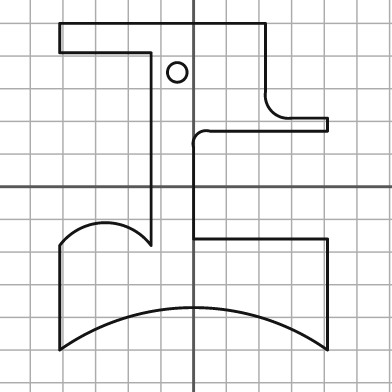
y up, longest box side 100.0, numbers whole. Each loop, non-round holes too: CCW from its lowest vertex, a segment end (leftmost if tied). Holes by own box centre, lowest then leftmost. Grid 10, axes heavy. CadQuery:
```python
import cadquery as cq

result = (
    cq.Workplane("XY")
    .moveTo(-41.0, -50.0)
    .threePointArc((0.0, -37.0), (41.0, -50.0))
    .lineTo(41.0, -16.0)
    .lineTo(0.0, -16.0)
    .lineTo(0.0, 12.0)
    .threePointArc((1.0, 16.0), (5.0, 17.0))
    .lineTo(41.0, 17.0)
    .lineTo(41.0, 21.0)
    .lineTo(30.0, 21.0)
    .threePointArc((24.0, 23.0), (22.0, 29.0))
    .lineTo(22.0, 50.0)
    .lineTo(-41.0, 50.0)
    .lineTo(-41.0, 41.0)
    .lineTo(-13.0, 41.0)
    .lineTo(-13.0, -18.0)
    .threePointArc((-27.0, -11.0), (-41.0, -18.0))
    .close()
    .moveTo(-5.0, 35.0)
    .circle(3.0)
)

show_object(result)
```